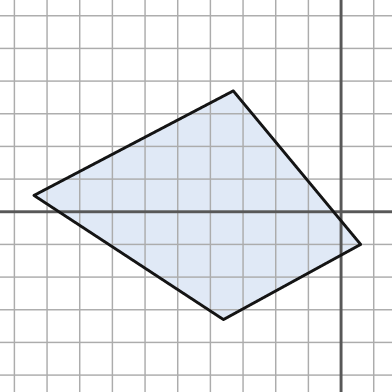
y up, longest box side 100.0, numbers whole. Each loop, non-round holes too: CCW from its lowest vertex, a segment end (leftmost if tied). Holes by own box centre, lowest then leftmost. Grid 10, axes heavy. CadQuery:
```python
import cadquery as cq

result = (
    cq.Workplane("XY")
    .moveTo(-36.0, -33.0)
    .lineTo(6.0, -10.0)
    .lineTo(-33.0, 37.0)
    .lineTo(-94.0, 5.0)
    .close()
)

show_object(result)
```